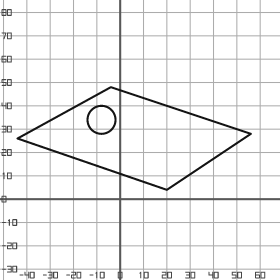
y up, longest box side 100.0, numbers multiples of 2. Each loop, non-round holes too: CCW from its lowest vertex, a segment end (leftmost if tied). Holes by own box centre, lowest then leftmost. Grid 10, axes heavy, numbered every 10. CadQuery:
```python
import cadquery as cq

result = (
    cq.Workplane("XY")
    .moveTo(20.0, 4.0)
    .lineTo(56.0, 28.0)
    .lineTo(-4.0, 48.0)
    .lineTo(-44.0, 26.0)
    .close()
    .moveTo(-8.0, 34.0)
    .circle(6.0)
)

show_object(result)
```